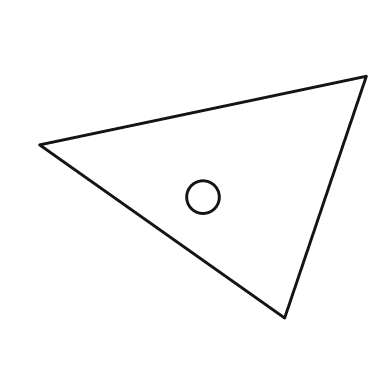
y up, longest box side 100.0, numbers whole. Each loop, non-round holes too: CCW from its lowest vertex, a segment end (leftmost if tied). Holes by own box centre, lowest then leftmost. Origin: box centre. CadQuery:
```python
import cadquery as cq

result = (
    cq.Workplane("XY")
    .moveTo(25.0, -37.0)
    .lineTo(50.0, 37.0)
    .lineTo(-50.0, 16.0)
    .close()
    .moveTo(0.0, 0.0)
    .circle(5.0)
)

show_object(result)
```